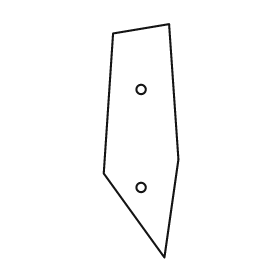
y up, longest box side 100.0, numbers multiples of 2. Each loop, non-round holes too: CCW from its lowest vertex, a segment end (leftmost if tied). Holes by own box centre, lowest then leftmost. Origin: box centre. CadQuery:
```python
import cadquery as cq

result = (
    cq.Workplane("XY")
    .moveTo(10.0, -50.0)
    .lineTo(16.0, -8.0)
    .lineTo(12.0, 50.0)
    .lineTo(-12.0, 46.0)
    .lineTo(-16.0, -14.0)
    .close()
    .moveTo(0.0, -20.0)
    .circle(2.0)
    .moveTo(0.0, 22.0)
    .circle(2.0)
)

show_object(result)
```